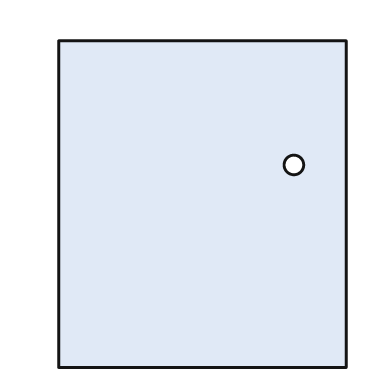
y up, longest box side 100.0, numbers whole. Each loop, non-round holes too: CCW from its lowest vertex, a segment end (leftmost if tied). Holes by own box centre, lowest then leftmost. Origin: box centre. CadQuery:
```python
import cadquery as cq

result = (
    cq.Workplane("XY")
    .moveTo(-44.0, -50.0)
    .lineTo(44.0, -50.0)
    .lineTo(44.0, 50.0)
    .lineTo(-44.0, 50.0)
    .close()
    .moveTo(28.0, 12.0)
    .circle(3.0)
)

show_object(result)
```